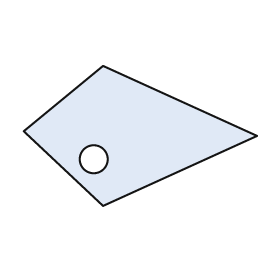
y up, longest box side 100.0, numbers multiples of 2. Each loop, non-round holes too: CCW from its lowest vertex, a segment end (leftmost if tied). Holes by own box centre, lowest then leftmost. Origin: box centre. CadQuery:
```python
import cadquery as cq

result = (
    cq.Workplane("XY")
    .moveTo(-16.0, -30.0)
    .lineTo(50.0, 0.0)
    .lineTo(-16.0, 30.0)
    .lineTo(-50.0, 2.0)
    .close()
    .moveTo(-20.0, -10.0)
    .circle(6.0)
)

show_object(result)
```